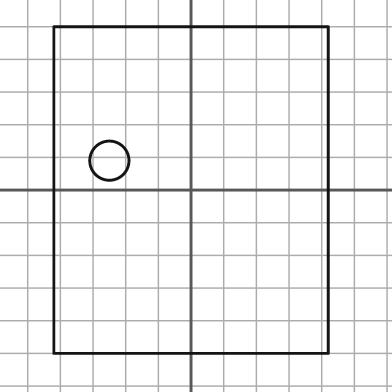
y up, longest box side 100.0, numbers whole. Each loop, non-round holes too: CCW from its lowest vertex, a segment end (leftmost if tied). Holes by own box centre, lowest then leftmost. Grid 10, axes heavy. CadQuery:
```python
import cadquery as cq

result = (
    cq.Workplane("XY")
    .moveTo(-42.0, -50.0)
    .lineTo(42.0, -50.0)
    .lineTo(42.0, 50.0)
    .lineTo(-42.0, 50.0)
    .close()
    .moveTo(-25.0, 9.0)
    .circle(6.0)
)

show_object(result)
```